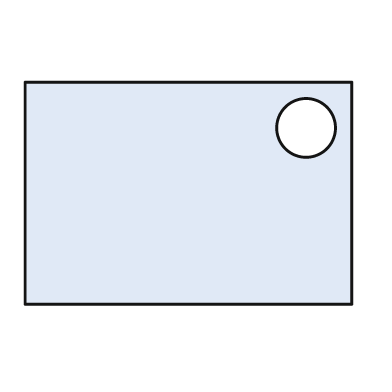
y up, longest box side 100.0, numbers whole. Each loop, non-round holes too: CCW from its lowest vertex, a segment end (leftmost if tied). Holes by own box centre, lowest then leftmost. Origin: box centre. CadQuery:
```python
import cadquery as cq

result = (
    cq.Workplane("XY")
    .moveTo(-50.0, -34.0)
    .lineTo(50.0, -34.0)
    .lineTo(50.0, 34.0)
    .lineTo(-50.0, 34.0)
    .close()
    .moveTo(36.0, 20.0)
    .circle(9.0)
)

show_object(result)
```